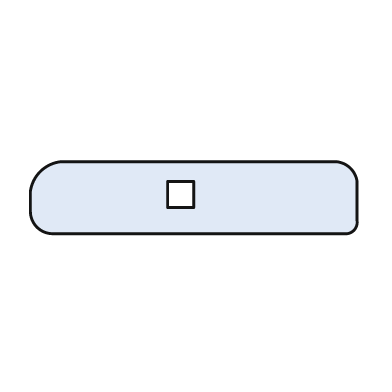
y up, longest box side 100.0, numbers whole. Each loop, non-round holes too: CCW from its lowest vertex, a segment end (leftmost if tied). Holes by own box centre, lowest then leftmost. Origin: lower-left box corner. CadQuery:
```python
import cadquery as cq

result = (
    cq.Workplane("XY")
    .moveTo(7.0, 0.0)
    .lineTo(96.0, 0.0)
    .threePointArc((99.0, 1.0), (100.0, 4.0))
    .lineTo(100.0, 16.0)
    .threePointArc((98.0, 20.0), (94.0, 22.0))
    .lineTo(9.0, 22.0)
    .threePointArc((3.0, 19.0), (0.0, 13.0))
    .lineTo(0.0, 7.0)
    .threePointArc((2.0, 2.0), (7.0, 0.0))
    .close()
    .moveTo(42.0, 8.0)
    .lineTo(50.0, 8.0)
    .lineTo(50.0, 16.0)
    .lineTo(42.0, 16.0)
    .close()
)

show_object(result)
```